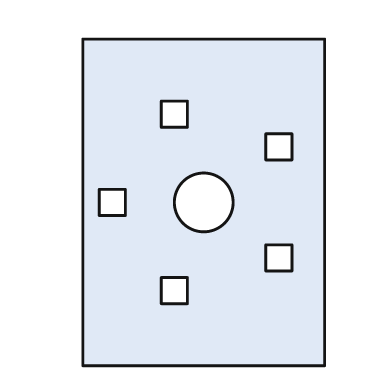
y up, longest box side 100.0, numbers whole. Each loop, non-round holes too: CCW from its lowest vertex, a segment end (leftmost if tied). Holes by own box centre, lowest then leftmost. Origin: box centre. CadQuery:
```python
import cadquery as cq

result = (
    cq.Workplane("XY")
    .moveTo(-37.0, -50.0)
    .lineTo(37.0, -50.0)
    .lineTo(37.0, 50.0)
    .lineTo(-37.0, 50.0)
    .close()
    .moveTo(-13.0, -31.0)
    .lineTo(-5.0, -31.0)
    .lineTo(-5.0, -23.0)
    .lineTo(-13.0, -23.0)
    .close()
    .moveTo(19.0, -21.0)
    .lineTo(27.0, -21.0)
    .lineTo(27.0, -13.0)
    .lineTo(19.0, -13.0)
    .close()
    .moveTo(-32.0, -4.0)
    .lineTo(-24.0, -4.0)
    .lineTo(-24.0, 4.0)
    .lineTo(-32.0, 4.0)
    .close()
    .moveTo(0.0, 0.0)
    .circle(9.0)
    .moveTo(19.0, 13.0)
    .lineTo(27.0, 13.0)
    .lineTo(27.0, 21.0)
    .lineTo(19.0, 21.0)
    .close()
    .moveTo(-13.0, 23.0)
    .lineTo(-5.0, 23.0)
    .lineTo(-5.0, 31.0)
    .lineTo(-13.0, 31.0)
    .close()
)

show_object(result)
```